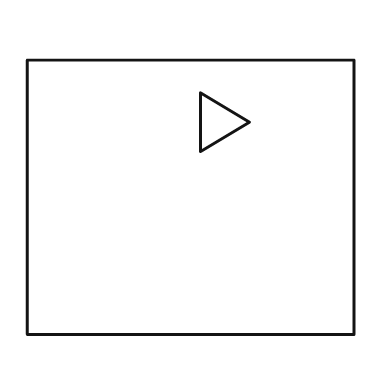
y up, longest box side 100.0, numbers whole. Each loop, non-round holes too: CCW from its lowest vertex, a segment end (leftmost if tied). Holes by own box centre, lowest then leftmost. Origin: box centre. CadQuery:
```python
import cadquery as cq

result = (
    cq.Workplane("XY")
    .moveTo(-50.0, -42.0)
    .lineTo(50.0, -42.0)
    .lineTo(50.0, 42.0)
    .lineTo(-50.0, 42.0)
    .close()
    .moveTo(3.0, 14.0)
    .lineTo(18.0, 23.0)
    .lineTo(3.0, 32.0)
    .close()
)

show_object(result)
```